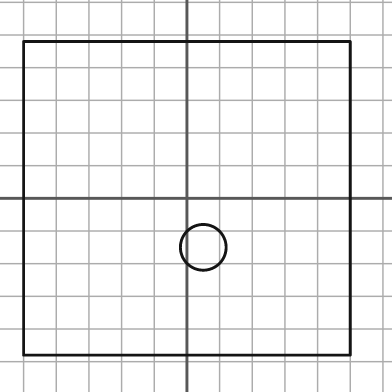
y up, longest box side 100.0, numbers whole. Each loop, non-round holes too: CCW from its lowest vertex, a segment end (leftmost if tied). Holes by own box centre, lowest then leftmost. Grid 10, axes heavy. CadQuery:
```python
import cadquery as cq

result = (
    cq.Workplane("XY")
    .moveTo(-50.0, -48.0)
    .lineTo(50.0, -48.0)
    .lineTo(50.0, 48.0)
    .lineTo(-50.0, 48.0)
    .close()
    .moveTo(5.0, -15.0)
    .circle(7.0)
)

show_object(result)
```